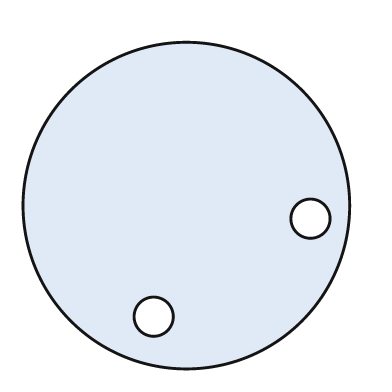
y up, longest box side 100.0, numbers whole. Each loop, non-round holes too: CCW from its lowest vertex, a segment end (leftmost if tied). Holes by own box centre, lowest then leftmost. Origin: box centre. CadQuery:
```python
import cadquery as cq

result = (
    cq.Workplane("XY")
    .moveTo(0.0, 0.0)
    .circle(50.0)
    .moveTo(-10.0, -34.0)
    .circle(6.0)
    .moveTo(38.0, -4.0)
    .circle(6.0)
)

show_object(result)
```